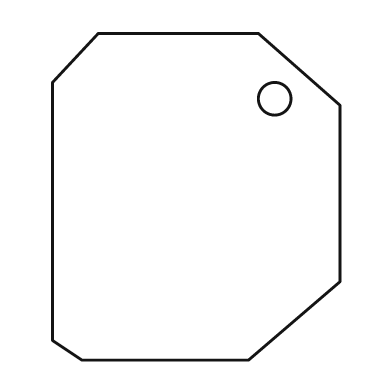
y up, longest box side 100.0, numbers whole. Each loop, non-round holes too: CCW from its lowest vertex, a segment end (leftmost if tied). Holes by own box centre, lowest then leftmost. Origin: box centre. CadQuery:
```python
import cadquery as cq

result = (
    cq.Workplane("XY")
    .moveTo(-35.0, -50.0)
    .lineTo(16.0, -50.0)
    .lineTo(44.0, -26.0)
    .lineTo(44.0, 28.0)
    .lineTo(19.0, 50.0)
    .lineTo(-30.0, 50.0)
    .lineTo(-44.0, 35.0)
    .lineTo(-44.0, -44.0)
    .close()
    .moveTo(24.0, 30.0)
    .circle(5.0)
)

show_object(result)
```